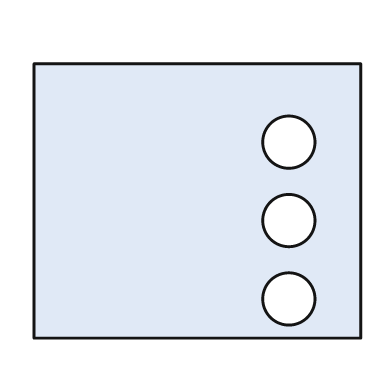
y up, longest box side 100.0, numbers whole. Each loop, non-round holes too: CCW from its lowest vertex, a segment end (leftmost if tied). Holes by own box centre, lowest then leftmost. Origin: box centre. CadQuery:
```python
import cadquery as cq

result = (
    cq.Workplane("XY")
    .moveTo(-50.0, -42.0)
    .lineTo(50.0, -42.0)
    .lineTo(50.0, 42.0)
    .lineTo(-50.0, 42.0)
    .close()
    .moveTo(28.0, -30.0)
    .circle(8.0)
    .moveTo(28.0, -6.0)
    .circle(8.0)
    .moveTo(28.0, 18.0)
    .circle(8.0)
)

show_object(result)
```